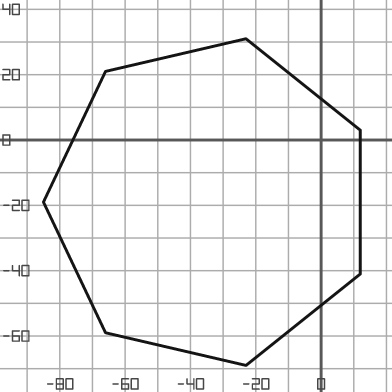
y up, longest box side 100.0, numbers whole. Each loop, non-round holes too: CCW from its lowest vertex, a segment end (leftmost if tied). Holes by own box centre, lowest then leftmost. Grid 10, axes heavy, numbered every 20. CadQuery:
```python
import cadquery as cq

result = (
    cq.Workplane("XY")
    .moveTo(-23.0, -69.0)
    .lineTo(12.0, -41.0)
    .lineTo(12.0, 3.0)
    .lineTo(-23.0, 31.0)
    .lineTo(-66.0, 21.0)
    .lineTo(-85.0, -19.0)
    .lineTo(-66.0, -59.0)
    .close()
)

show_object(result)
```